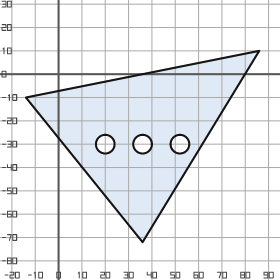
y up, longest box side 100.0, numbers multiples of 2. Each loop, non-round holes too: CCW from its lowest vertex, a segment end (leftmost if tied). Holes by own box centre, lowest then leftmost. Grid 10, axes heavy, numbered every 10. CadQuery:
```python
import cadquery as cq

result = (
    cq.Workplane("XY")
    .moveTo(36.0, -72.0)
    .lineTo(86.0, 10.0)
    .lineTo(-14.0, -10.0)
    .close()
    .moveTo(20.0, -30.0)
    .circle(4.0)
    .moveTo(36.0, -30.0)
    .circle(4.0)
    .moveTo(52.0, -30.0)
    .circle(4.0)
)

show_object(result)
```